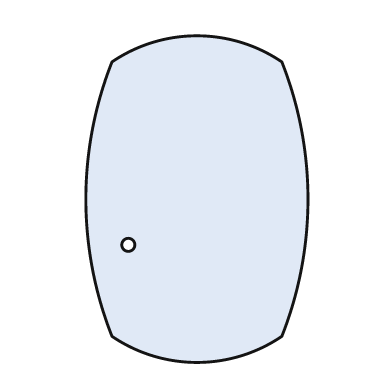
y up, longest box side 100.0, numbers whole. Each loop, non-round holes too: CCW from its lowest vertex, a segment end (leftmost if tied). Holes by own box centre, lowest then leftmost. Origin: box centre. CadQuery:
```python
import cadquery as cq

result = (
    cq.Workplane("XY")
    .moveTo(-26.0, -42.0)
    .threePointArc((0.0, -50.0), (26.0, -42.0))
    .threePointArc((34.0, 0.0), (26.0, 42.0))
    .threePointArc((0.0, 50.0), (-26.0, 42.0))
    .threePointArc((-34.0, 0.0), (-26.0, -42.0))
    .close()
    .moveTo(-21.0, -14.0)
    .circle(2.0)
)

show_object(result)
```